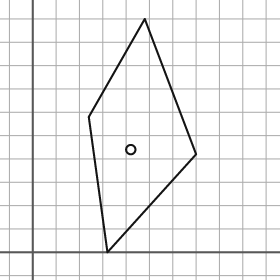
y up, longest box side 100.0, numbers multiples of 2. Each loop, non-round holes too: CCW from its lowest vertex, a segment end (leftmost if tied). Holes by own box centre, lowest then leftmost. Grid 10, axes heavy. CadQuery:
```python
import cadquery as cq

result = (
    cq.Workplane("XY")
    .moveTo(32.0, 0.0)
    .lineTo(70.0, 42.0)
    .lineTo(48.0, 100.0)
    .lineTo(24.0, 58.0)
    .close()
    .moveTo(42.0, 44.0)
    .circle(2.0)
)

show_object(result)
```